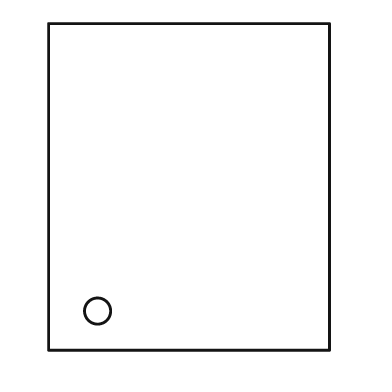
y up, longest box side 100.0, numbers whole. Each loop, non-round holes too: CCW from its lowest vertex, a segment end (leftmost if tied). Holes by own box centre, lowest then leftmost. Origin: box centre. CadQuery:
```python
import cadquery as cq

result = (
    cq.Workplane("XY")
    .moveTo(-43.0, -50.0)
    .lineTo(43.0, -50.0)
    .lineTo(43.0, 50.0)
    .lineTo(-43.0, 50.0)
    .close()
    .moveTo(-28.0, -38.0)
    .circle(4.0)
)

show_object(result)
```